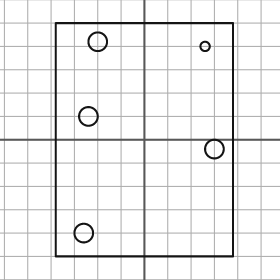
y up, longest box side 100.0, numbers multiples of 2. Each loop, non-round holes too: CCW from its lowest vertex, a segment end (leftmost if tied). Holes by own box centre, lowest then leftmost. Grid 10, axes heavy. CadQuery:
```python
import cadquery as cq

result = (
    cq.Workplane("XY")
    .moveTo(-38.0, -50.0)
    .lineTo(38.0, -50.0)
    .lineTo(38.0, 50.0)
    .lineTo(-38.0, 50.0)
    .close()
    .moveTo(-26.0, -40.0)
    .circle(4.0)
    .moveTo(30.0, -4.0)
    .circle(4.0)
    .moveTo(-24.0, 10.0)
    .circle(4.0)
    .moveTo(26.0, 40.0)
    .circle(2.0)
    .moveTo(-20.0, 42.0)
    .circle(4.0)
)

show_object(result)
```